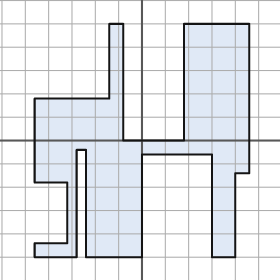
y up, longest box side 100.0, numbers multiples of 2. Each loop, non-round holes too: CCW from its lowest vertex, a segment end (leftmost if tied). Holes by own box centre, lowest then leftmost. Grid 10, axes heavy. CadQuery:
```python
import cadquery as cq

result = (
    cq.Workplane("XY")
    .moveTo(-46.0, -50.0)
    .lineTo(-28.0, -50.0)
    .lineTo(-28.0, -4.0)
    .lineTo(-24.0, -4.0)
    .lineTo(-24.0, -50.0)
    .lineTo(0.0, -50.0)
    .lineTo(0.0, -6.0)
    .lineTo(30.0, -6.0)
    .lineTo(30.0, -50.0)
    .lineTo(40.0, -50.0)
    .lineTo(40.0, -14.0)
    .lineTo(46.0, -14.0)
    .lineTo(46.0, 50.0)
    .lineTo(18.0, 50.0)
    .lineTo(18.0, 0.0)
    .lineTo(-8.0, 0.0)
    .lineTo(-8.0, 50.0)
    .lineTo(-14.0, 50.0)
    .lineTo(-14.0, 18.0)
    .lineTo(-46.0, 18.0)
    .lineTo(-46.0, -18.0)
    .lineTo(-32.0, -18.0)
    .lineTo(-32.0, -44.0)
    .lineTo(-46.0, -44.0)
    .close()
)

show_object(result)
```